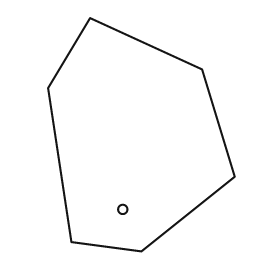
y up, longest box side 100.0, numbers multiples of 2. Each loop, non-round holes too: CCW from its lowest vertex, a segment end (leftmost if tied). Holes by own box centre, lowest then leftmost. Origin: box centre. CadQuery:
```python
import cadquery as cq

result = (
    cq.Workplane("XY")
    .moveTo(0.0, -50.0)
    .lineTo(40.0, -18.0)
    .lineTo(26.0, 28.0)
    .lineTo(-22.0, 50.0)
    .lineTo(-40.0, 20.0)
    .lineTo(-30.0, -46.0)
    .close()
    .moveTo(-8.0, -32.0)
    .circle(2.0)
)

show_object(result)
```